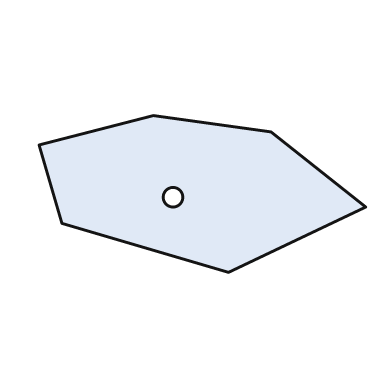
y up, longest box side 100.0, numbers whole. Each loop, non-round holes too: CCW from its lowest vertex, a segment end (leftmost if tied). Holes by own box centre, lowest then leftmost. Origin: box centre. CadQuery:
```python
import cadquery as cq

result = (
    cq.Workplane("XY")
    .moveTo(8.0, -24.0)
    .lineTo(50.0, -4.0)
    .lineTo(21.0, 19.0)
    .lineTo(-15.0, 24.0)
    .lineTo(-50.0, 15.0)
    .lineTo(-43.0, -9.0)
    .close()
    .moveTo(-9.0, -1.0)
    .circle(3.0)
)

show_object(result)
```